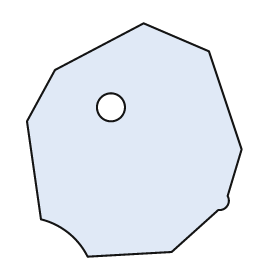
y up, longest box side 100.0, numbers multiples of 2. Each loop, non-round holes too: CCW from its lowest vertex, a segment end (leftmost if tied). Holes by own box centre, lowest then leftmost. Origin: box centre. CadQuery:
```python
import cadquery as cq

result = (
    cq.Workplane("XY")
    .moveTo(-20.0, -50.0)
    .lineTo(16.0, -48.0)
    .lineTo(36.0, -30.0)
    .threePointArc((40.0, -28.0), (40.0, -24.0))
    .lineTo(46.0, -4.0)
    .lineTo(32.0, 38.0)
    .lineTo(4.0, 50.0)
    .lineTo(-34.0, 30.0)
    .lineTo(-46.0, 8.0)
    .lineTo(-40.0, -34.0)
    .threePointArc((-28.0, -40.0), (-20.0, -50.0))
    .close()
    .moveTo(-10.0, 14.0)
    .circle(6.0)
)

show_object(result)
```